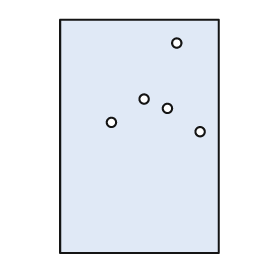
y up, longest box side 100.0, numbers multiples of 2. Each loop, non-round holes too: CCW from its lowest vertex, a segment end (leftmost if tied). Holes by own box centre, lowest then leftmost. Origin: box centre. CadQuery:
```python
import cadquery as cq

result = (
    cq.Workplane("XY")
    .moveTo(-34.0, -50.0)
    .lineTo(34.0, -50.0)
    .lineTo(34.0, 50.0)
    .lineTo(-34.0, 50.0)
    .close()
    .moveTo(26.0, 2.0)
    .circle(2.0)
    .moveTo(-12.0, 6.0)
    .circle(2.0)
    .moveTo(12.0, 12.0)
    .circle(2.0)
    .moveTo(2.0, 16.0)
    .circle(2.0)
    .moveTo(16.0, 40.0)
    .circle(2.0)
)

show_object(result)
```